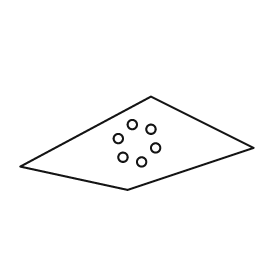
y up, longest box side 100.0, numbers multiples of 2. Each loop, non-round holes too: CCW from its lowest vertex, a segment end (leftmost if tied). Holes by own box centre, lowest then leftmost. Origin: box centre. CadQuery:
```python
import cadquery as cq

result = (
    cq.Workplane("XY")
    .moveTo(-4.0, -20.0)
    .lineTo(50.0, -2.0)
    .lineTo(6.0, 20.0)
    .lineTo(-50.0, -10.0)
    .close()
    .moveTo(2.0, -8.0)
    .circle(2.0)
    .moveTo(-6.0, -6.0)
    .circle(2.0)
    .moveTo(8.0, -2.0)
    .circle(2.0)
    .moveTo(-8.0, 2.0)
    .circle(2.0)
    .moveTo(6.0, 6.0)
    .circle(2.0)
    .moveTo(-2.0, 8.0)
    .circle(2.0)
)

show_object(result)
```